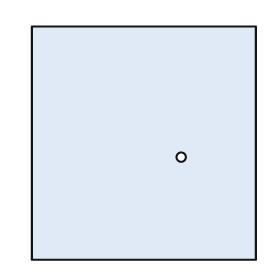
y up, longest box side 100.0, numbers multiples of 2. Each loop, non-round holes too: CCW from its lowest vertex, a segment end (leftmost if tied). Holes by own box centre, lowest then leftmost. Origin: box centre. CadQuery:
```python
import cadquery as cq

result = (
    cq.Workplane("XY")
    .moveTo(-48.0, -50.0)
    .lineTo(48.0, -50.0)
    .lineTo(48.0, 50.0)
    .lineTo(-48.0, 50.0)
    .close()
    .moveTo(16.0, -6.0)
    .circle(2.0)
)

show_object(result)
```